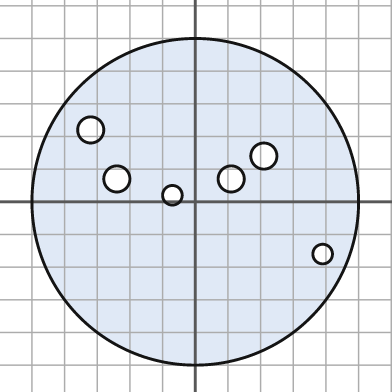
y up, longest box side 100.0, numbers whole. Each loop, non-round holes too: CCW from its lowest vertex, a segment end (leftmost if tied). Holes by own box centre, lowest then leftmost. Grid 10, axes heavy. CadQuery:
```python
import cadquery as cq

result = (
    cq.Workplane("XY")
    .moveTo(0.0, 0.0)
    .circle(50.0)
    .moveTo(39.0, -16.0)
    .circle(3.0)
    .moveTo(-7.0, 2.0)
    .circle(3.0)
    .moveTo(-24.0, 7.0)
    .circle(4.0)
    .moveTo(11.0, 7.0)
    .circle(4.0)
    .moveTo(21.0, 14.0)
    .circle(4.0)
    .moveTo(-32.0, 22.0)
    .circle(4.0)
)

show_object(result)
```